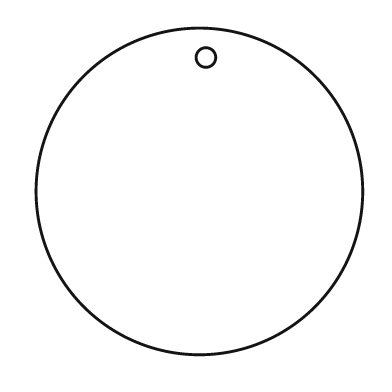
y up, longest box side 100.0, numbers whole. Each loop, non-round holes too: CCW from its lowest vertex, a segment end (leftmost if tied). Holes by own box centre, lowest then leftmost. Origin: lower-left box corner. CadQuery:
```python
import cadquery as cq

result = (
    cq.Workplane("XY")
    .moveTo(50.0, 50.0)
    .circle(50.0)
    .moveTo(52.0, 91.0)
    .circle(3.0)
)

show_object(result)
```